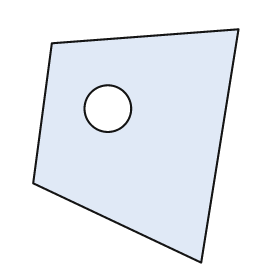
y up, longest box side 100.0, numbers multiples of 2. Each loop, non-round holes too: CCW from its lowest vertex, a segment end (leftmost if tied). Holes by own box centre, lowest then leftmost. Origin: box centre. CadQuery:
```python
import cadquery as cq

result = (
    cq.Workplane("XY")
    .moveTo(28.0, -50.0)
    .lineTo(44.0, 50.0)
    .lineTo(-36.0, 44.0)
    .lineTo(-44.0, -16.0)
    .close()
    .moveTo(-12.0, 16.0)
    .circle(10.0)
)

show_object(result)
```